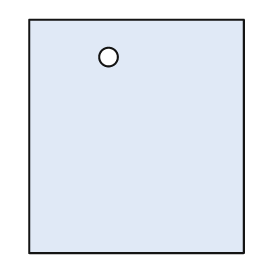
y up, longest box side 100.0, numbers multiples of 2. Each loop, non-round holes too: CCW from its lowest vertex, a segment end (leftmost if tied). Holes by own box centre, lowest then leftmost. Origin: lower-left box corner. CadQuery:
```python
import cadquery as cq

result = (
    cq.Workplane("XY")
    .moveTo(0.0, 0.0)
    .lineTo(92.0, 0.0)
    .lineTo(92.0, 100.0)
    .lineTo(0.0, 100.0)
    .close()
    .moveTo(34.0, 84.0)
    .circle(4.0)
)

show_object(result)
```